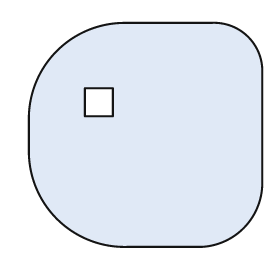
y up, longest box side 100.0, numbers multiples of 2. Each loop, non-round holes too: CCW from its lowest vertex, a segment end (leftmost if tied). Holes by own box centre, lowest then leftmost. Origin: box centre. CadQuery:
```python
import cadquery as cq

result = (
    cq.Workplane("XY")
    .moveTo(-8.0, -48.0)
    .lineTo(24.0, -48.0)
    .threePointArc((42.0, -40.0), (50.0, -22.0))
    .lineTo(50.0, 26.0)
    .threePointArc((44.0, 42.0), (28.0, 48.0))
    .lineTo(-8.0, 48.0)
    .threePointArc((-38.0, 36.0), (-50.0, 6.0))
    .lineTo(-50.0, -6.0)
    .threePointArc((-38.0, -36.0), (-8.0, -48.0))
    .close()
    .moveTo(-26.0, 8.0)
    .lineTo(-14.0, 8.0)
    .lineTo(-14.0, 20.0)
    .lineTo(-26.0, 20.0)
    .close()
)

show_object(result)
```